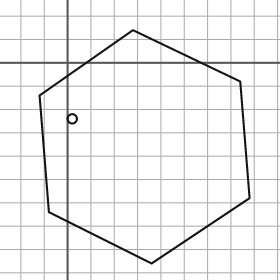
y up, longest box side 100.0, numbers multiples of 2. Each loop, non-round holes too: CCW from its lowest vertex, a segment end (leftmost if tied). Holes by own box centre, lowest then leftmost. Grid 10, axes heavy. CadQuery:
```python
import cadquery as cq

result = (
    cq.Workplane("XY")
    .moveTo(36.0, -86.0)
    .lineTo(78.0, -58.0)
    .lineTo(74.0, -8.0)
    .lineTo(28.0, 14.0)
    .lineTo(-12.0, -14.0)
    .lineTo(-8.0, -64.0)
    .close()
    .moveTo(2.0, -24.0)
    .circle(2.0)
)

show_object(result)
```